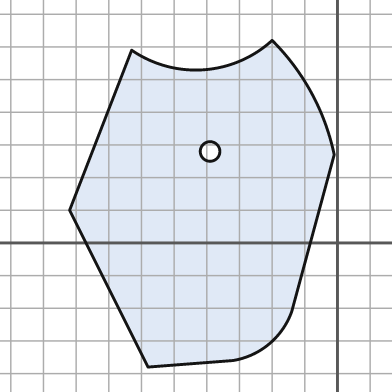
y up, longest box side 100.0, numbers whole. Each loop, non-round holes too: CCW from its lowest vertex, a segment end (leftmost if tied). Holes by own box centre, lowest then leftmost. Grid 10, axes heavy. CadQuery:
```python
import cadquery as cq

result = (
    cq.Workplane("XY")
    .moveTo(-58.0, -38.0)
    .lineTo(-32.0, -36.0)
    .threePointArc((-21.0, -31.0), (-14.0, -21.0))
    .lineTo(-1.0, 27.0)
    .threePointArc((-8.0, 46.0), (-20.0, 62.0))
    .threePointArc((-41.0, 53.0), (-63.0, 59.0))
    .lineTo(-82.0, 10.0)
    .close()
    .moveTo(-39.0, 28.0)
    .circle(3.0)
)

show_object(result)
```